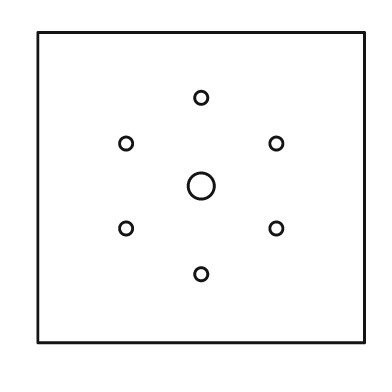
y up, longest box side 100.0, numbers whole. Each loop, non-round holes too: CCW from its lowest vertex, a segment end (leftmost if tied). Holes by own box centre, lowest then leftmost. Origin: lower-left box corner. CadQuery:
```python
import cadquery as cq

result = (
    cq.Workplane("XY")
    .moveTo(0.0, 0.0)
    .lineTo(100.0, 0.0)
    .lineTo(100.0, 95.0)
    .lineTo(0.0, 95.0)
    .close()
    .moveTo(50.0, 21.0)
    .circle(2.0)
    .moveTo(27.0, 35.0)
    .circle(2.0)
    .moveTo(73.0, 35.0)
    .circle(2.0)
    .moveTo(50.0, 48.0)
    .circle(4.0)
    .moveTo(27.0, 61.0)
    .circle(2.0)
    .moveTo(73.0, 61.0)
    .circle(2.0)
    .moveTo(50.0, 75.0)
    .circle(2.0)
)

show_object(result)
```